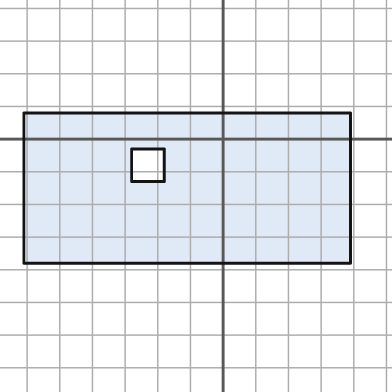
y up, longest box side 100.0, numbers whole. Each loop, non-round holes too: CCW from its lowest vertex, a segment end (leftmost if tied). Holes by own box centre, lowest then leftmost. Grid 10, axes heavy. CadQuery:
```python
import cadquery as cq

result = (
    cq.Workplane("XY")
    .moveTo(-61.0, -38.0)
    .lineTo(39.0, -38.0)
    .lineTo(39.0, 8.0)
    .lineTo(-61.0, 8.0)
    .close()
    .moveTo(-28.0, -13.0)
    .lineTo(-18.0, -13.0)
    .lineTo(-18.0, -3.0)
    .lineTo(-28.0, -3.0)
    .close()
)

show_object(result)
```